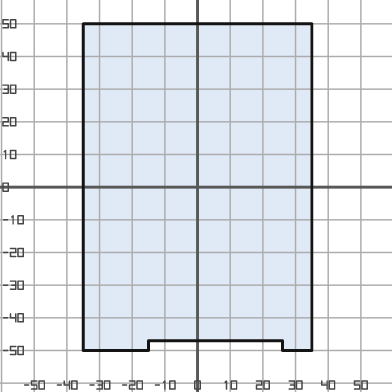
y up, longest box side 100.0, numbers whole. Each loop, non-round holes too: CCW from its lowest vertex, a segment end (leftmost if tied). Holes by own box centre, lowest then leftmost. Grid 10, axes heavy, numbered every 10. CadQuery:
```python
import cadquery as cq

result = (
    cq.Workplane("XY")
    .moveTo(-35.0, -50.0)
    .lineTo(-15.0, -50.0)
    .lineTo(-15.0, -47.0)
    .lineTo(26.0, -47.0)
    .lineTo(26.0, -50.0)
    .lineTo(35.0, -50.0)
    .lineTo(35.0, 50.0)
    .lineTo(-35.0, 50.0)
    .close()
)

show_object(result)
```